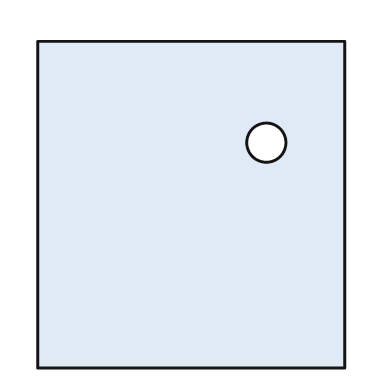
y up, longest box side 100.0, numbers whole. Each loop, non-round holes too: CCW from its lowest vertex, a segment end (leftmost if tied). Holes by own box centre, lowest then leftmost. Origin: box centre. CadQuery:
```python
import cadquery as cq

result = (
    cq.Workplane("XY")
    .moveTo(-47.0, -50.0)
    .lineTo(47.0, -50.0)
    .lineTo(47.0, 50.0)
    .lineTo(-47.0, 50.0)
    .close()
    .moveTo(23.0, 19.0)
    .circle(6.0)
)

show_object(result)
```